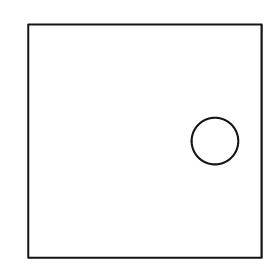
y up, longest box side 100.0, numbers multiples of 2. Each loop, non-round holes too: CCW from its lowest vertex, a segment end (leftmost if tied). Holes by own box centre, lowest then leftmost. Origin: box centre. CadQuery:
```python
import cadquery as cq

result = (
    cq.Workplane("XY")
    .moveTo(-50.0, -50.0)
    .lineTo(50.0, -50.0)
    .lineTo(50.0, 50.0)
    .lineTo(-50.0, 50.0)
    .close()
    .moveTo(30.0, 0.0)
    .circle(10.0)
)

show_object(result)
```